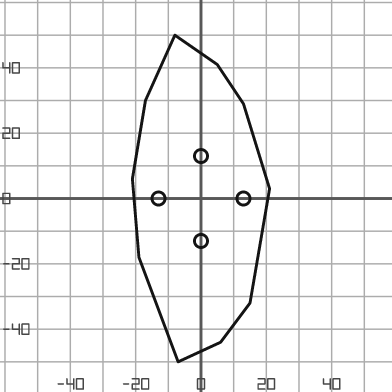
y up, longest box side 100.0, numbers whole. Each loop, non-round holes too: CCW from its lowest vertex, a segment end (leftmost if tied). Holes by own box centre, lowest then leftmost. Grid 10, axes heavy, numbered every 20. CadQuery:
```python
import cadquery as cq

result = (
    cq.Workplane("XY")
    .moveTo(-7.0, -50.0)
    .lineTo(6.0, -44.0)
    .lineTo(15.0, -32.0)
    .lineTo(21.0, 3.0)
    .lineTo(13.0, 29.0)
    .lineTo(5.0, 41.0)
    .lineTo(-8.0, 50.0)
    .lineTo(-17.0, 30.0)
    .lineTo(-21.0, 6.0)
    .lineTo(-19.0, -18.0)
    .close()
    .moveTo(0.0, -13.0)
    .circle(2.0)
    .moveTo(-13.0, 0.0)
    .circle(2.0)
    .moveTo(13.0, 0.0)
    .circle(2.0)
    .moveTo(0.0, 13.0)
    .circle(2.0)
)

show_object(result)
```